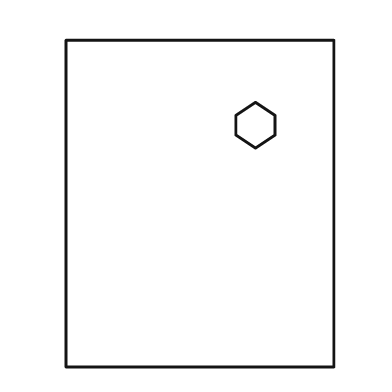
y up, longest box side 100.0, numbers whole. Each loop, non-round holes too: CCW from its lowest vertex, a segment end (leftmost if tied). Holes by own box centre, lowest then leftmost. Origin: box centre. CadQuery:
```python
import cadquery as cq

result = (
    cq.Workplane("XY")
    .moveTo(-41.0, -50.0)
    .lineTo(41.0, -50.0)
    .lineTo(41.0, 50.0)
    .lineTo(-41.0, 50.0)
    .close()
    .moveTo(17.0, 17.0)
    .lineTo(23.0, 21.0)
    .lineTo(23.0, 27.0)
    .lineTo(17.0, 31.0)
    .lineTo(11.0, 27.0)
    .lineTo(11.0, 21.0)
    .close()
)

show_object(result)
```